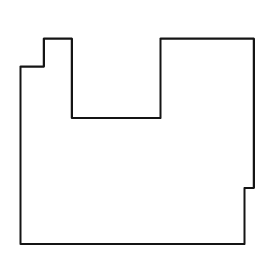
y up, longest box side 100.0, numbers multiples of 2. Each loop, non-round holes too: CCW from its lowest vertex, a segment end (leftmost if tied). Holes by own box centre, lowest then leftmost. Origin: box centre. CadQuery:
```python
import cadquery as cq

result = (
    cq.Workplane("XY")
    .moveTo(-50.0, -44.0)
    .lineTo(46.0, -44.0)
    .lineTo(46.0, -20.0)
    .lineTo(50.0, -20.0)
    .lineTo(50.0, 44.0)
    .lineTo(10.0, 44.0)
    .lineTo(10.0, 10.0)
    .lineTo(-28.0, 10.0)
    .lineTo(-28.0, 44.0)
    .lineTo(-40.0, 44.0)
    .lineTo(-40.0, 32.0)
    .lineTo(-50.0, 32.0)
    .close()
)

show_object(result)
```